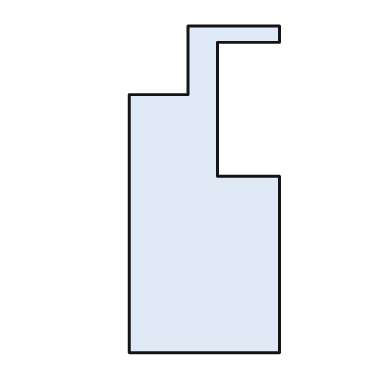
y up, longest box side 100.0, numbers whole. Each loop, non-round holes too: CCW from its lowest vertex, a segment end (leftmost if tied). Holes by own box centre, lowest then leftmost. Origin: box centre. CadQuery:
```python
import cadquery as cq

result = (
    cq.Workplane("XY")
    .moveTo(-23.0, -50.0)
    .lineTo(23.0, -50.0)
    .lineTo(23.0, 4.0)
    .lineTo(4.0, 4.0)
    .lineTo(4.0, 45.0)
    .lineTo(23.0, 45.0)
    .lineTo(23.0, 50.0)
    .lineTo(-5.0, 50.0)
    .lineTo(-5.0, 29.0)
    .lineTo(-23.0, 29.0)
    .close()
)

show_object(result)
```